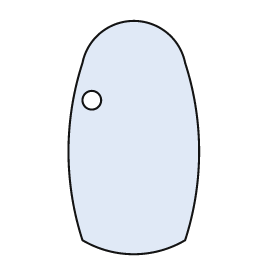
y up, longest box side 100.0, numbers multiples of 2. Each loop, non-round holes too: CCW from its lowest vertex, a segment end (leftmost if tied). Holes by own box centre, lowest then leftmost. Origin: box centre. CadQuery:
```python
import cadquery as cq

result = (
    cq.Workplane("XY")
    .moveTo(-22.0, -44.0)
    .threePointArc((0.0, -50.0), (22.0, -44.0))
    .threePointArc((28.0, -6.0), (22.0, 32.0))
    .threePointArc((0.0, 50.0), (-22.0, 32.0))
    .threePointArc((-28.0, -6.0), (-22.0, -44.0))
    .close()
    .moveTo(-18.0, 16.0)
    .circle(4.0)
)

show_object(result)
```